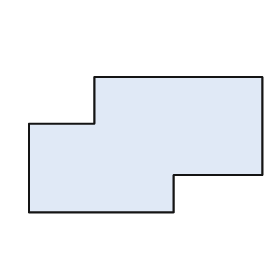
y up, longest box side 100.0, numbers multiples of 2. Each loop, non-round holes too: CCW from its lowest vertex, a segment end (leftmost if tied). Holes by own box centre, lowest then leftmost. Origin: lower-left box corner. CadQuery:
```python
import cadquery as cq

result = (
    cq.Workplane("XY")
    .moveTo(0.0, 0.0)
    .lineTo(62.0, 0.0)
    .lineTo(62.0, 16.0)
    .lineTo(100.0, 16.0)
    .lineTo(100.0, 58.0)
    .lineTo(28.0, 58.0)
    .lineTo(28.0, 38.0)
    .lineTo(0.0, 38.0)
    .close()
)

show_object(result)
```